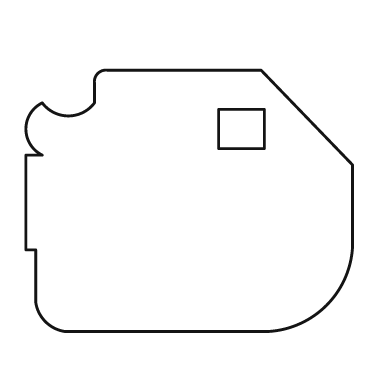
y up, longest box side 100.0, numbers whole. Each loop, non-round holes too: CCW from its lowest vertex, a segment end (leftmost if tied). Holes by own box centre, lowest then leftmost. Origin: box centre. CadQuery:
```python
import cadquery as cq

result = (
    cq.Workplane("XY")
    .moveTo(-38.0, -40.0)
    .lineTo(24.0, -40.0)
    .threePointArc((42.0, -32.0), (50.0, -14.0))
    .lineTo(50.0, 11.0)
    .lineTo(22.0, 40.0)
    .lineTo(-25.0, 40.0)
    .threePointArc((-28.0, 39.0), (-29.0, 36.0))
    .lineTo(-29.0, 30.0)
    .threePointArc((-37.0, 26.0), (-45.0, 30.0))
    .threePointArc((-50.0, 22.0), (-45.0, 14.0))
    .lineTo(-50.0, 14.0)
    .lineTo(-50.0, -15.0)
    .lineTo(-47.0, -15.0)
    .lineTo(-47.0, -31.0)
    .threePointArc((-44.0, -37.0), (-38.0, -40.0))
    .close()
    .moveTo(9.0, 16.0)
    .lineTo(23.0, 16.0)
    .lineTo(23.0, 28.0)
    .lineTo(9.0, 28.0)
    .close()
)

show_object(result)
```